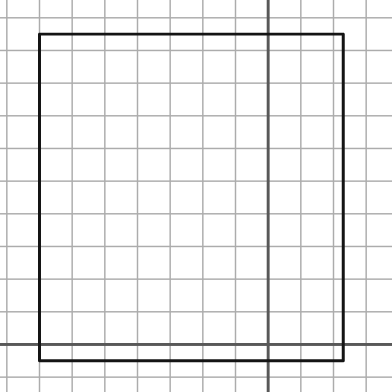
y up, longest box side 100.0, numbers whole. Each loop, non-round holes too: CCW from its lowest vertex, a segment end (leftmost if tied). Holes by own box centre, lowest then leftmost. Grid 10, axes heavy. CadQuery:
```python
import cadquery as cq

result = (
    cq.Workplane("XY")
    .moveTo(-70.0, -5.0)
    .lineTo(23.0, -5.0)
    .lineTo(23.0, 95.0)
    .lineTo(-70.0, 95.0)
    .close()
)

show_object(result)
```